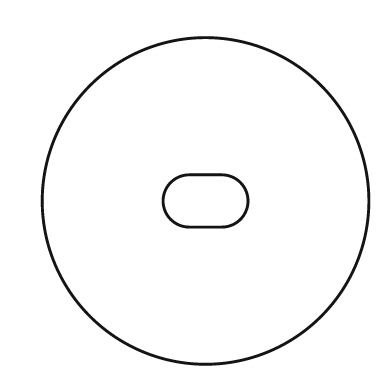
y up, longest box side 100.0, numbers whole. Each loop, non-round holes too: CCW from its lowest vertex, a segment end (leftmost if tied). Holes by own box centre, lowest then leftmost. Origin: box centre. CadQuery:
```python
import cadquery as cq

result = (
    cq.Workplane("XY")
    .moveTo(0.0, 0.0)
    .circle(50.0)
    .moveTo(-5.0, -8.0)
    .lineTo(5.0, -8.0)
    .threePointArc((13.0, 0.0), (5.0, 8.0))
    .lineTo(-5.0, 8.0)
    .threePointArc((-13.0, 0.0), (-5.0, -8.0))
    .close()
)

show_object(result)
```